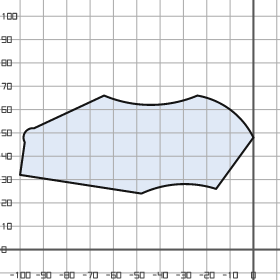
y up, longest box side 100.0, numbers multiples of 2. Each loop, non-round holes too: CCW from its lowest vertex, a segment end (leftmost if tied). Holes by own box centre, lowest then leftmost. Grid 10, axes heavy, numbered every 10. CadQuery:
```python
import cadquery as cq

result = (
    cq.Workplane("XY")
    .moveTo(-48.0, 24.0)
    .threePointArc((-32.0, 28.0), (-16.0, 26.0))
    .lineTo(0.0, 48.0)
    .threePointArc((-10.0, 60.0), (-24.0, 66.0))
    .threePointArc((-44.0, 62.0), (-64.0, 66.0))
    .lineTo(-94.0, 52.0)
    .threePointArc((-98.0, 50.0), (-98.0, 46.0))
    .lineTo(-100.0, 32.0)
    .close()
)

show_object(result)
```